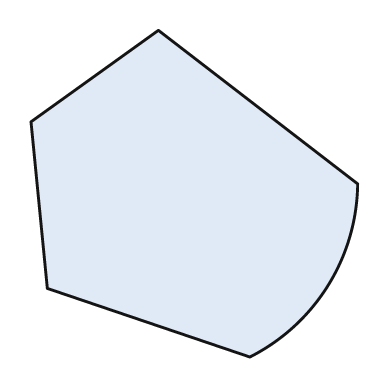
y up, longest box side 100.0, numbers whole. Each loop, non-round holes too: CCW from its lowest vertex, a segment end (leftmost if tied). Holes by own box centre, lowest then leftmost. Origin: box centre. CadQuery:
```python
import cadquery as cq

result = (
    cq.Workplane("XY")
    .moveTo(17.0, -50.0)
    .threePointArc((41.0, -28.0), (50.0, 3.0))
    .lineTo(-11.0, 50.0)
    .lineTo(-50.0, 22.0)
    .lineTo(-45.0, -29.0)
    .close()
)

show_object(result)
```